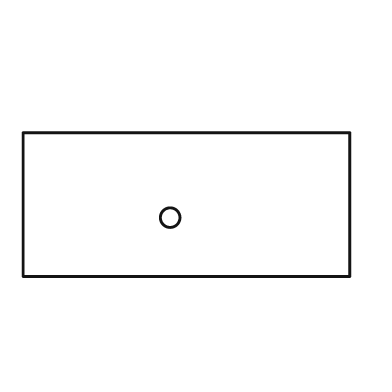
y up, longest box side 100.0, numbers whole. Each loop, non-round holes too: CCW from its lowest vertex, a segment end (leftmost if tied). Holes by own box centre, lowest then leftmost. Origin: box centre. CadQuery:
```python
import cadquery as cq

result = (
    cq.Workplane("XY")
    .moveTo(-50.0, -22.0)
    .lineTo(50.0, -22.0)
    .lineTo(50.0, 22.0)
    .lineTo(-50.0, 22.0)
    .close()
    .moveTo(-5.0, -4.0)
    .circle(3.0)
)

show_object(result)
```